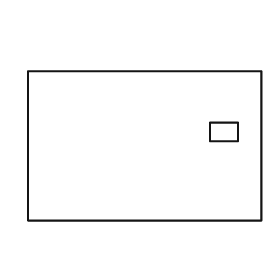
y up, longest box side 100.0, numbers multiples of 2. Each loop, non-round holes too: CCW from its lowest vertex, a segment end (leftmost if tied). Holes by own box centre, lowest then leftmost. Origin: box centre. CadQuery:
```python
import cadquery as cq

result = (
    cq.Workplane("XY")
    .moveTo(-50.0, -32.0)
    .lineTo(50.0, -32.0)
    .lineTo(50.0, 32.0)
    .lineTo(-50.0, 32.0)
    .close()
    .moveTo(28.0, 2.0)
    .lineTo(40.0, 2.0)
    .lineTo(40.0, 10.0)
    .lineTo(28.0, 10.0)
    .close()
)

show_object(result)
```